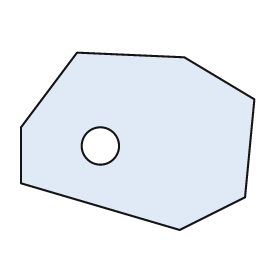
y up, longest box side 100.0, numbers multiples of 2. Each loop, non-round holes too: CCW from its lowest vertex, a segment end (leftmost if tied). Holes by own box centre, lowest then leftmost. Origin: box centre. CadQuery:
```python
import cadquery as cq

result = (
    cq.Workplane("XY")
    .moveTo(18.0, -38.0)
    .lineTo(46.0, -24.0)
    .lineTo(50.0, 18.0)
    .lineTo(20.0, 36.0)
    .lineTo(-26.0, 38.0)
    .lineTo(-50.0, 6.0)
    .lineTo(-50.0, -18.0)
    .close()
    .moveTo(-16.0, -2.0)
    .circle(8.0)
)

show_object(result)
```